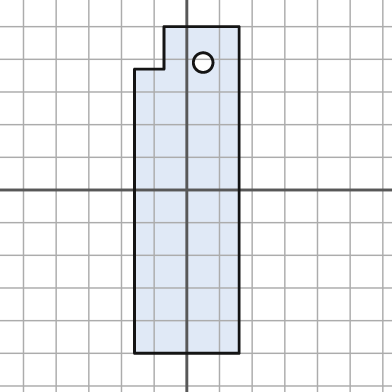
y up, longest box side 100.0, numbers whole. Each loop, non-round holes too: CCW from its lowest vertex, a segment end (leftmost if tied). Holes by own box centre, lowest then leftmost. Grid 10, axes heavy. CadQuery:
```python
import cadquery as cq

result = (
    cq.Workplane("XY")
    .moveTo(-16.0, -50.0)
    .lineTo(16.0, -50.0)
    .lineTo(16.0, 50.0)
    .lineTo(-7.0, 50.0)
    .lineTo(-7.0, 37.0)
    .lineTo(-16.0, 37.0)
    .close()
    .moveTo(5.0, 39.0)
    .circle(3.0)
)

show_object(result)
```